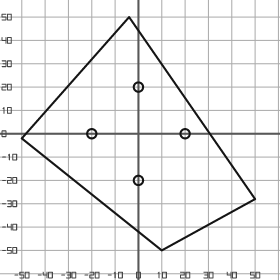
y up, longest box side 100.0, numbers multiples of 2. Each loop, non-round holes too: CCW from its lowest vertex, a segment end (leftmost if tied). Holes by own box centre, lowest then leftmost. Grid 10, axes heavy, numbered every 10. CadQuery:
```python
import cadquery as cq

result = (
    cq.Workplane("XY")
    .moveTo(10.0, -50.0)
    .lineTo(50.0, -28.0)
    .lineTo(-4.0, 50.0)
    .lineTo(-50.0, -2.0)
    .close()
    .moveTo(0.0, -20.0)
    .circle(2.0)
    .moveTo(-20.0, 0.0)
    .circle(2.0)
    .moveTo(20.0, 0.0)
    .circle(2.0)
    .moveTo(0.0, 20.0)
    .circle(2.0)
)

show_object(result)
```